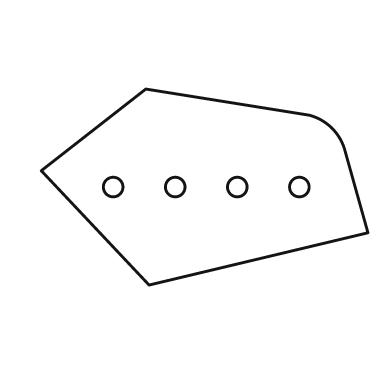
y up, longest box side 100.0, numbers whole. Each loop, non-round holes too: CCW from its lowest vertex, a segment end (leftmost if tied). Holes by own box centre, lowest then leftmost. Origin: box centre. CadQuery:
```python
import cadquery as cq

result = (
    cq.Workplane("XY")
    .moveTo(-17.0, -30.0)
    .lineTo(50.0, -14.0)
    .lineTo(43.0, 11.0)
    .threePointArc((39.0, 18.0), (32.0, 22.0))
    .lineTo(-18.0, 30.0)
    .lineTo(-50.0, 5.0)
    .close()
    .moveTo(-28.0, 0.0)
    .circle(3.0)
    .moveTo(-9.0, 0.0)
    .circle(3.0)
    .moveTo(10.0, 0.0)
    .circle(3.0)
    .moveTo(29.0, 0.0)
    .circle(3.0)
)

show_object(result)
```